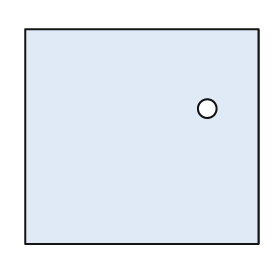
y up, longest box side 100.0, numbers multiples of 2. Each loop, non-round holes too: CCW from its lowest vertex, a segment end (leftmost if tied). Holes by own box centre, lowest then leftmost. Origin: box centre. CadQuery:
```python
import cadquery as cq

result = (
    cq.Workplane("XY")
    .moveTo(-50.0, -46.0)
    .lineTo(50.0, -46.0)
    .lineTo(50.0, 46.0)
    .lineTo(-50.0, 46.0)
    .close()
    .moveTo(28.0, 12.0)
    .circle(4.0)
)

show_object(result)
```